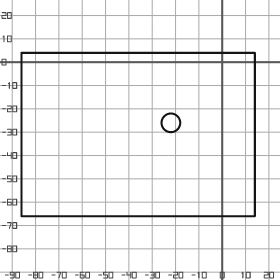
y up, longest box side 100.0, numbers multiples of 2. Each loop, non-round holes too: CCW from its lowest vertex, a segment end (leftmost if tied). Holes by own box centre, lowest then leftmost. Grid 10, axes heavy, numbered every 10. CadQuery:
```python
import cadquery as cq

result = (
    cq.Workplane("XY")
    .moveTo(-86.0, -66.0)
    .lineTo(14.0, -66.0)
    .lineTo(14.0, 4.0)
    .lineTo(-86.0, 4.0)
    .close()
    .moveTo(-22.0, -26.0)
    .circle(4.0)
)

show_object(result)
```